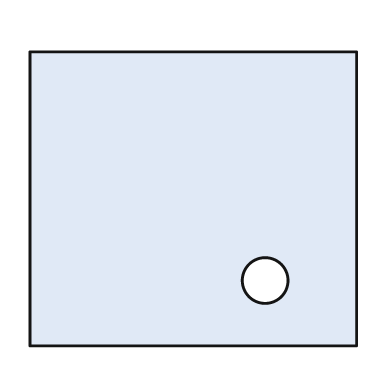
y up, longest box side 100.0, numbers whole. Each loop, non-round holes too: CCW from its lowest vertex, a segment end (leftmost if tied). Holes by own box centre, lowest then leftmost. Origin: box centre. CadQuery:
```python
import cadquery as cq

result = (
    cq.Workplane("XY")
    .moveTo(-50.0, -45.0)
    .lineTo(50.0, -45.0)
    .lineTo(50.0, 45.0)
    .lineTo(-50.0, 45.0)
    .close()
    .moveTo(22.0, -25.0)
    .circle(7.0)
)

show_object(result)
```